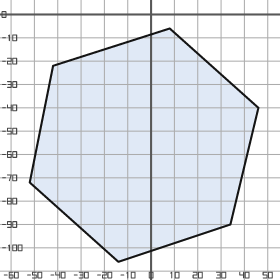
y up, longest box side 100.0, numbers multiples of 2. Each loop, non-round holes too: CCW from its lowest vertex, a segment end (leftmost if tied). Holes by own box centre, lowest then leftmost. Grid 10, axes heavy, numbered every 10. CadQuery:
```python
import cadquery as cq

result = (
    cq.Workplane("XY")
    .moveTo(-14.0, -106.0)
    .lineTo(34.0, -90.0)
    .lineTo(46.0, -40.0)
    .lineTo(8.0, -6.0)
    .lineTo(-42.0, -22.0)
    .lineTo(-52.0, -72.0)
    .close()
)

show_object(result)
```